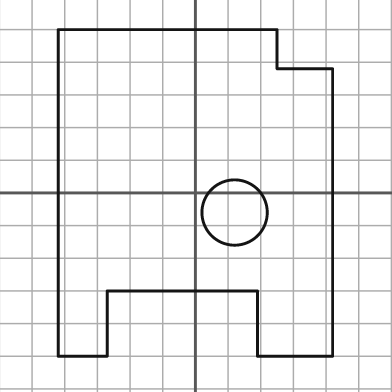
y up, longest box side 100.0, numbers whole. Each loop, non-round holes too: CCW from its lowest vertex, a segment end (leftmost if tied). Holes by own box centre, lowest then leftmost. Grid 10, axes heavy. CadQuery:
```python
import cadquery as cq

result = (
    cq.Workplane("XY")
    .moveTo(-42.0, -50.0)
    .lineTo(-27.0, -50.0)
    .lineTo(-27.0, -30.0)
    .lineTo(19.0, -30.0)
    .lineTo(19.0, -50.0)
    .lineTo(42.0, -50.0)
    .lineTo(42.0, 38.0)
    .lineTo(25.0, 38.0)
    .lineTo(25.0, 50.0)
    .lineTo(-42.0, 50.0)
    .close()
    .moveTo(12.0, -6.0)
    .circle(10.0)
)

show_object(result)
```